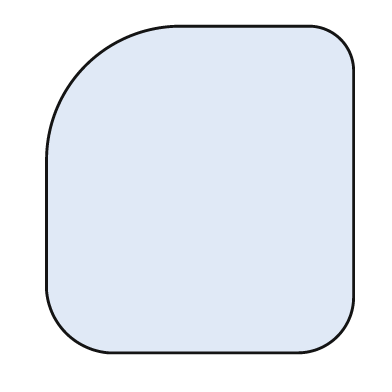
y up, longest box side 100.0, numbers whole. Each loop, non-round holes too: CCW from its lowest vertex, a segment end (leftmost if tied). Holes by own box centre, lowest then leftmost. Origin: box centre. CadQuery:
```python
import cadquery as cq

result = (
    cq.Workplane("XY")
    .moveTo(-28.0, -50.0)
    .lineTo(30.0, -50.0)
    .threePointArc((42.0, -45.0), (47.0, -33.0))
    .lineTo(47.0, 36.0)
    .threePointArc((43.0, 46.0), (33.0, 50.0))
    .lineTo(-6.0, 50.0)
    .threePointArc((-35.0, 38.0), (-47.0, 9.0))
    .lineTo(-47.0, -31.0)
    .threePointArc((-41.0, -44.0), (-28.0, -50.0))
    .close()
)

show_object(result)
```